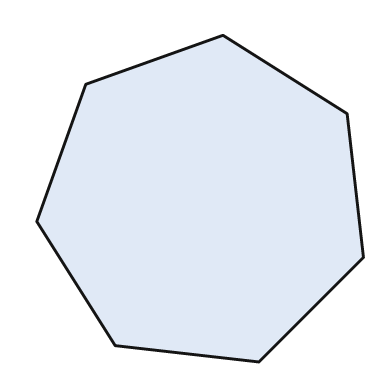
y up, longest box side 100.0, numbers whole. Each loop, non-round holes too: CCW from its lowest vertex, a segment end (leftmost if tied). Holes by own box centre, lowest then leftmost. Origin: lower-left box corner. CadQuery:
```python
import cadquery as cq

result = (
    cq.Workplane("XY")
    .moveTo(68.0, 0.0)
    .lineTo(100.0, 32.0)
    .lineTo(95.0, 76.0)
    .lineTo(57.0, 100.0)
    .lineTo(15.0, 85.0)
    .lineTo(0.0, 43.0)
    .lineTo(24.0, 5.0)
    .close()
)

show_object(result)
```